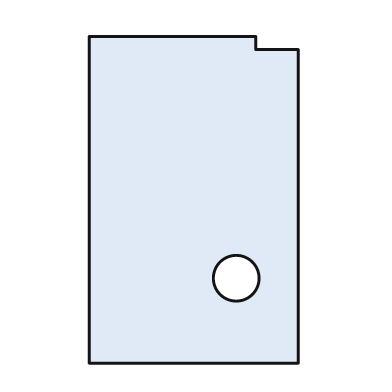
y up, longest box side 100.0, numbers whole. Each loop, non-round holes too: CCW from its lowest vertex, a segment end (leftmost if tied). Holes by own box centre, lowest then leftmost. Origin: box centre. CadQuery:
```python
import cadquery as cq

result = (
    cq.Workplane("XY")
    .moveTo(-32.0, -50.0)
    .lineTo(32.0, -50.0)
    .lineTo(32.0, 46.0)
    .lineTo(19.0, 46.0)
    .lineTo(19.0, 50.0)
    .lineTo(-32.0, 50.0)
    .close()
    .moveTo(13.0, -24.0)
    .circle(7.0)
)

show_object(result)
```